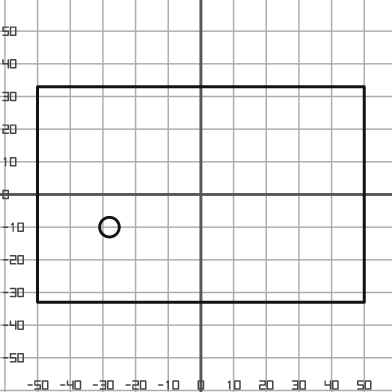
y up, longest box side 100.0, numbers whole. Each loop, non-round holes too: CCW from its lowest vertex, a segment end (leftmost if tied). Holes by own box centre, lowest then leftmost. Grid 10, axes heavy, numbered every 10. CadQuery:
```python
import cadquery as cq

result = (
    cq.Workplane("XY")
    .moveTo(-50.0, -33.0)
    .lineTo(50.0, -33.0)
    .lineTo(50.0, 33.0)
    .lineTo(-50.0, 33.0)
    .close()
    .moveTo(-28.0, -10.0)
    .circle(3.0)
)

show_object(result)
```